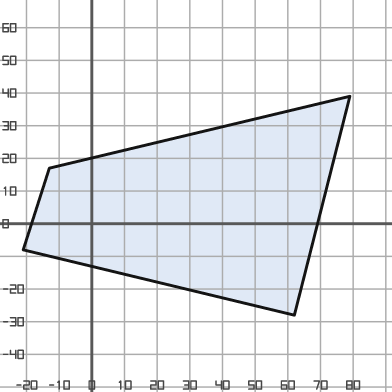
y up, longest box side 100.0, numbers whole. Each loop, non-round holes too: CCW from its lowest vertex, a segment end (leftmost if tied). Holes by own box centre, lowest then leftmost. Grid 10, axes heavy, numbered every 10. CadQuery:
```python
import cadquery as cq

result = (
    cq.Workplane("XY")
    .moveTo(62.0, -28.0)
    .lineTo(79.0, 39.0)
    .lineTo(-13.0, 17.0)
    .lineTo(-21.0, -8.0)
    .close()
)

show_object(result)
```